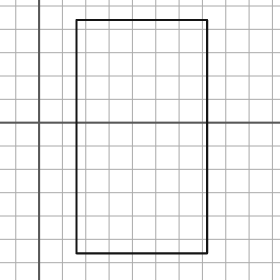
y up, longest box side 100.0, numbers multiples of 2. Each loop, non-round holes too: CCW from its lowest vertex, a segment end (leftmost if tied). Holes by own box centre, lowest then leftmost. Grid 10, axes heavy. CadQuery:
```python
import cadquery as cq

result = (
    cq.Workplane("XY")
    .moveTo(16.0, -56.0)
    .lineTo(72.0, -56.0)
    .lineTo(72.0, 44.0)
    .lineTo(16.0, 44.0)
    .close()
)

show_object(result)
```